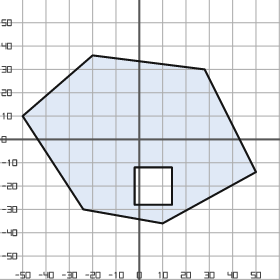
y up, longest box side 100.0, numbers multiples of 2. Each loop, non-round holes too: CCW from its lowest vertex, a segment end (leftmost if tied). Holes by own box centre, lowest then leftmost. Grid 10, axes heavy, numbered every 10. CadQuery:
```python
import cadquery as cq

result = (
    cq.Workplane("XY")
    .moveTo(10.0, -36.0)
    .lineTo(50.0, -14.0)
    .lineTo(28.0, 30.0)
    .lineTo(-20.0, 36.0)
    .lineTo(-50.0, 10.0)
    .lineTo(-24.0, -30.0)
    .close()
    .moveTo(-2.0, -28.0)
    .lineTo(14.0, -28.0)
    .lineTo(14.0, -12.0)
    .lineTo(-2.0, -12.0)
    .close()
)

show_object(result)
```